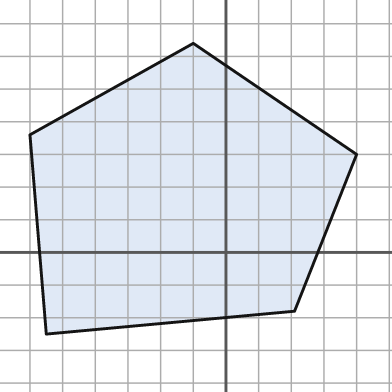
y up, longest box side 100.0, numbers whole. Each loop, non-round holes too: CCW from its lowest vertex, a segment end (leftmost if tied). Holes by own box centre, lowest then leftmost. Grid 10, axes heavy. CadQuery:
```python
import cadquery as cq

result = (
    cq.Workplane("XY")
    .moveTo(-55.0, -25.0)
    .lineTo(21.0, -18.0)
    .lineTo(40.0, 30.0)
    .lineTo(-10.0, 64.0)
    .lineTo(-60.0, 36.0)
    .close()
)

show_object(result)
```